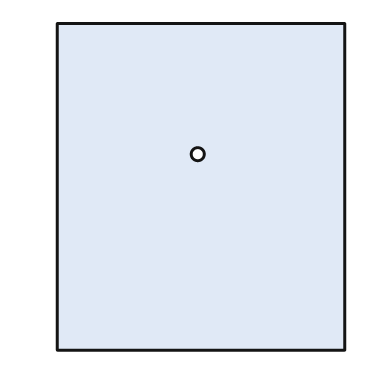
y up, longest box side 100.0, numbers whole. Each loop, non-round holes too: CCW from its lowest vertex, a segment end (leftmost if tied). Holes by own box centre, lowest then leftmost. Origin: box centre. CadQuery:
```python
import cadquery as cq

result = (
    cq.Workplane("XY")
    .moveTo(-44.0, -50.0)
    .lineTo(44.0, -50.0)
    .lineTo(44.0, 50.0)
    .lineTo(-44.0, 50.0)
    .close()
    .moveTo(-1.0, 10.0)
    .circle(2.0)
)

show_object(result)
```